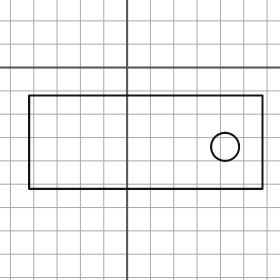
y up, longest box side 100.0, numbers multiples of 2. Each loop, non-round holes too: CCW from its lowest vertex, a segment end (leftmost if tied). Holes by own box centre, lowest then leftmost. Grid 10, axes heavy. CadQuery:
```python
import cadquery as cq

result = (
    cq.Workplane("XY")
    .moveTo(-42.0, -52.0)
    .lineTo(58.0, -52.0)
    .lineTo(58.0, -12.0)
    .lineTo(-42.0, -12.0)
    .close()
    .moveTo(42.0, -34.0)
    .circle(6.0)
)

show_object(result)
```